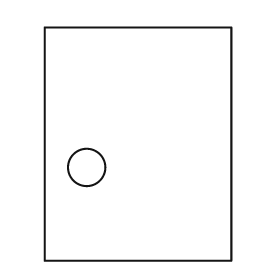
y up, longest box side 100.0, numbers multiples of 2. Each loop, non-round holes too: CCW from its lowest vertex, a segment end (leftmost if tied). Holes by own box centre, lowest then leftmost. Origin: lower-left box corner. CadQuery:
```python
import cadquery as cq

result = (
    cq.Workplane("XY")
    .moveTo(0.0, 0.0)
    .lineTo(80.0, 0.0)
    .lineTo(80.0, 100.0)
    .lineTo(0.0, 100.0)
    .close()
    .moveTo(18.0, 40.0)
    .circle(8.0)
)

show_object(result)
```